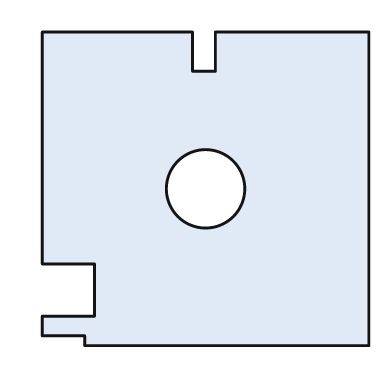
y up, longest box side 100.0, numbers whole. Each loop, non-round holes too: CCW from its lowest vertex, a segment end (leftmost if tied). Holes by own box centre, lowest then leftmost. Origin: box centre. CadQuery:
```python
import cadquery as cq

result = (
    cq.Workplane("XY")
    .moveTo(-37.0, -48.0)
    .lineTo(50.0, -48.0)
    .lineTo(50.0, 48.0)
    .lineTo(3.0, 48.0)
    .lineTo(3.0, 36.0)
    .lineTo(-4.0, 36.0)
    .lineTo(-4.0, 48.0)
    .lineTo(-50.0, 48.0)
    .lineTo(-50.0, -23.0)
    .lineTo(-34.0, -23.0)
    .lineTo(-34.0, -39.0)
    .lineTo(-50.0, -39.0)
    .lineTo(-50.0, -45.0)
    .lineTo(-37.0, -45.0)
    .close()
    .moveTo(0.0, 0.0)
    .circle(12.0)
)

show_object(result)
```